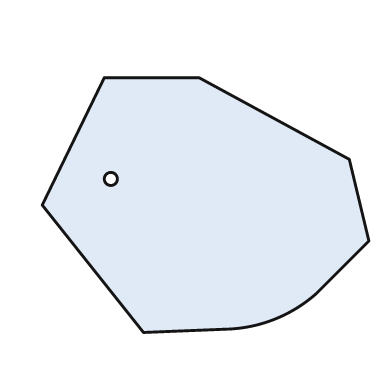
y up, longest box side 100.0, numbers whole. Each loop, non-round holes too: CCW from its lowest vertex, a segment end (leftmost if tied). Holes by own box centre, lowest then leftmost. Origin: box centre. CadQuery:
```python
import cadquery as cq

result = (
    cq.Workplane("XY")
    .moveTo(-19.0, -39.0)
    .lineTo(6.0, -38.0)
    .threePointArc((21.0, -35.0), (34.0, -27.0))
    .lineTo(50.0, -11.0)
    .lineTo(44.0, 14.0)
    .lineTo(-2.0, 39.0)
    .lineTo(-31.0, 39.0)
    .lineTo(-50.0, 0.0)
    .close()
    .moveTo(-29.0, 8.0)
    .circle(2.0)
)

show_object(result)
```